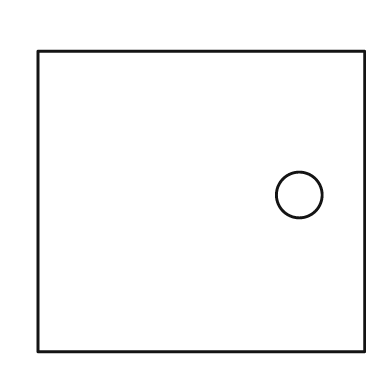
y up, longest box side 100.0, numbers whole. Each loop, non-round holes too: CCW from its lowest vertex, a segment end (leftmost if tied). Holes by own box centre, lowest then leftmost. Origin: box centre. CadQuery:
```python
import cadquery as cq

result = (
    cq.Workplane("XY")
    .moveTo(-50.0, -46.0)
    .lineTo(50.0, -46.0)
    .lineTo(50.0, 46.0)
    .lineTo(-50.0, 46.0)
    .close()
    .moveTo(30.0, 2.0)
    .circle(7.0)
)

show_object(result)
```